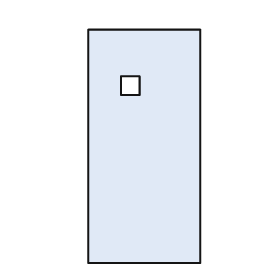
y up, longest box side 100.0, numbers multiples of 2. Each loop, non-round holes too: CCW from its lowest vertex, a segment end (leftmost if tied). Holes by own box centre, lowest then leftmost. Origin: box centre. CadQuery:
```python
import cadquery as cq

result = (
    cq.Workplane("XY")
    .moveTo(-24.0, -50.0)
    .lineTo(24.0, -50.0)
    .lineTo(24.0, 50.0)
    .lineTo(-24.0, 50.0)
    .close()
    .moveTo(-10.0, 22.0)
    .lineTo(-2.0, 22.0)
    .lineTo(-2.0, 30.0)
    .lineTo(-10.0, 30.0)
    .close()
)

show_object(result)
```